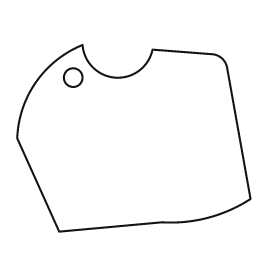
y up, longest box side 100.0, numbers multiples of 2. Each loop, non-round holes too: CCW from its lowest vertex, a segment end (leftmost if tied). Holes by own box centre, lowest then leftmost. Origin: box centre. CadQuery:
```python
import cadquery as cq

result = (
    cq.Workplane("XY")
    .moveTo(-32.0, -40.0)
    .lineTo(12.0, -36.0)
    .threePointArc((32.0, -34.0), (50.0, -26.0))
    .lineTo(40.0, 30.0)
    .threePointArc((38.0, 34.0), (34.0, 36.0))
    .lineTo(8.0, 38.0)
    .threePointArc((-8.0, 26.0), (-22.0, 40.0))
    .threePointArc((-42.0, 24.0), (-50.0, 0.0))
    .close()
    .moveTo(-26.0, 26.0)
    .circle(4.0)
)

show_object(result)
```